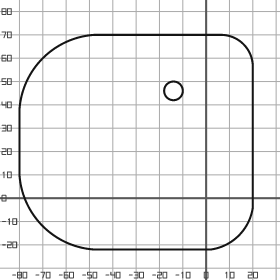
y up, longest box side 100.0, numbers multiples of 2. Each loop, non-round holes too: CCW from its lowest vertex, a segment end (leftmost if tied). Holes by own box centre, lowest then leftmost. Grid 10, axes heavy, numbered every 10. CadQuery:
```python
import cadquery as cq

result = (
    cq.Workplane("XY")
    .moveTo(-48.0, -22.0)
    .lineTo(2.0, -22.0)
    .threePointArc((14.0, -16.0), (20.0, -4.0))
    .lineTo(20.0, 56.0)
    .threePointArc((16.0, 66.0), (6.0, 70.0))
    .lineTo(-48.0, 70.0)
    .threePointArc((-70.0, 60.0), (-80.0, 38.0))
    .lineTo(-80.0, 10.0)
    .threePointArc((-70.0, -12.0), (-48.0, -22.0))
    .close()
    .moveTo(-14.0, 46.0)
    .circle(4.0)
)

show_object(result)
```